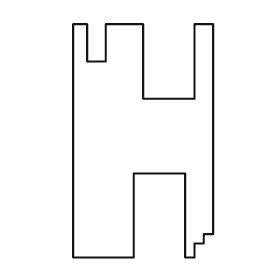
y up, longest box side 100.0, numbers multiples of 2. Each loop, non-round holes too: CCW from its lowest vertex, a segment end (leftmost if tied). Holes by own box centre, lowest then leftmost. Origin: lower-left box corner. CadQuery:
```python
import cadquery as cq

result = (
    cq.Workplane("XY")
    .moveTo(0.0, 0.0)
    .lineTo(26.0, 0.0)
    .lineTo(26.0, 36.0)
    .lineTo(48.0, 36.0)
    .lineTo(48.0, 0.0)
    .lineTo(52.0, 0.0)
    .lineTo(52.0, 6.0)
    .lineTo(56.0, 6.0)
    .lineTo(56.0, 10.0)
    .lineTo(60.0, 10.0)
    .lineTo(60.0, 100.0)
    .lineTo(52.0, 100.0)
    .lineTo(52.0, 68.0)
    .lineTo(30.0, 68.0)
    .lineTo(30.0, 100.0)
    .lineTo(14.0, 100.0)
    .lineTo(14.0, 84.0)
    .lineTo(6.0, 84.0)
    .lineTo(6.0, 100.0)
    .lineTo(0.0, 100.0)
    .close()
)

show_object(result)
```